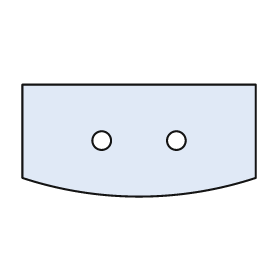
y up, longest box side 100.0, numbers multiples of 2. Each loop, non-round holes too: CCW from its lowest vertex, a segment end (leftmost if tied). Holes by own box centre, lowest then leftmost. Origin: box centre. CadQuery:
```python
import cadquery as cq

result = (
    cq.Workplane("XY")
    .moveTo(-50.0, -16.0)
    .threePointArc((0.0, -24.0), (50.0, -16.0))
    .lineTo(50.0, 24.0)
    .lineTo(-50.0, 24.0)
    .close()
    .moveTo(-16.0, 0.0)
    .circle(4.0)
    .moveTo(16.0, 0.0)
    .circle(4.0)
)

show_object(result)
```